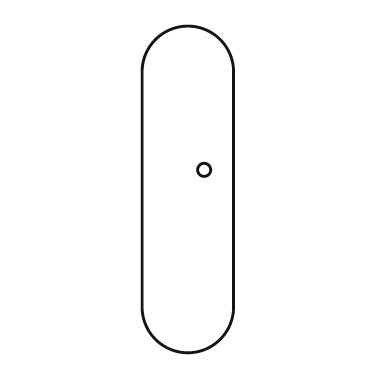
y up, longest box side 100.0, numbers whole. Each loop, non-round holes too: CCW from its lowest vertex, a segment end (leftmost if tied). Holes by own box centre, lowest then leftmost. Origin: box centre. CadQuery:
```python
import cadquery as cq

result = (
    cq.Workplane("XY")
    .moveTo(-14.0, -36.0)
    .threePointArc((0.0, -50.0), (14.0, -36.0))
    .lineTo(14.0, 36.0)
    .threePointArc((0.0, 50.0), (-14.0, 36.0))
    .close()
    .moveTo(5.0, 6.0)
    .circle(2.0)
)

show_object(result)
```